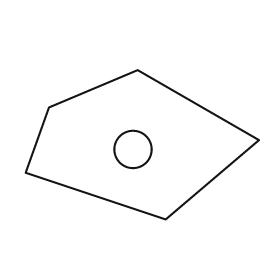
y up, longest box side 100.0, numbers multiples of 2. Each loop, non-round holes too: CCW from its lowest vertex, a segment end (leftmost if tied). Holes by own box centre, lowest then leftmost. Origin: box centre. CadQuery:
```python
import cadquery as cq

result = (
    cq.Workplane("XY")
    .moveTo(10.0, -32.0)
    .lineTo(50.0, 2.0)
    .lineTo(-2.0, 32.0)
    .lineTo(-40.0, 16.0)
    .lineTo(-50.0, -12.0)
    .close()
    .moveTo(-4.0, -2.0)
    .circle(8.0)
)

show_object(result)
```